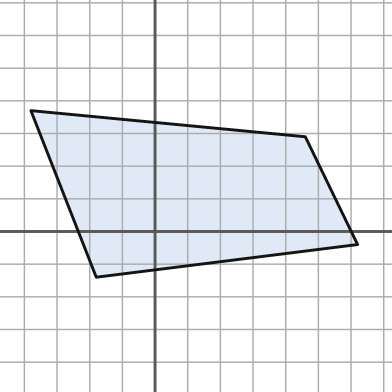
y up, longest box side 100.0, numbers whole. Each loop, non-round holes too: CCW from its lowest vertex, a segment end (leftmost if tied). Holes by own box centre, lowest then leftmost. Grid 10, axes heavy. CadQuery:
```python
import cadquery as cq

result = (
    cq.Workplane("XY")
    .moveTo(-18.0, -14.0)
    .lineTo(62.0, -4.0)
    .lineTo(46.0, 29.0)
    .lineTo(-38.0, 37.0)
    .close()
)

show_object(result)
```